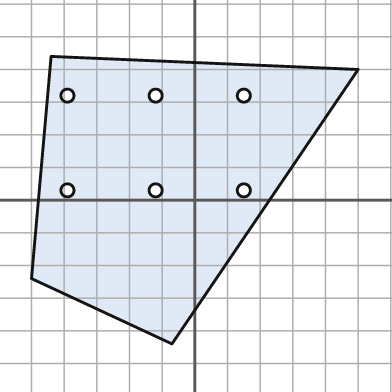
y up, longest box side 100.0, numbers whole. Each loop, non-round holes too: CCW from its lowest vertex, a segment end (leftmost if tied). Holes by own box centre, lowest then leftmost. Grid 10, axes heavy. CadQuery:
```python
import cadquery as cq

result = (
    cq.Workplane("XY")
    .moveTo(-7.0, -44.0)
    .lineTo(50.0, 40.0)
    .lineTo(-44.0, 44.0)
    .lineTo(-50.0, -24.0)
    .close()
    .moveTo(-39.0, 3.0)
    .circle(2.0)
    .moveTo(-12.0, 3.0)
    .circle(2.0)
    .moveTo(15.0, 3.0)
    .circle(2.0)
    .moveTo(-39.0, 32.0)
    .circle(2.0)
    .moveTo(-12.0, 32.0)
    .circle(2.0)
    .moveTo(15.0, 32.0)
    .circle(2.0)
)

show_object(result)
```